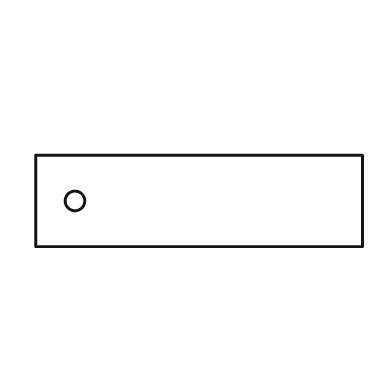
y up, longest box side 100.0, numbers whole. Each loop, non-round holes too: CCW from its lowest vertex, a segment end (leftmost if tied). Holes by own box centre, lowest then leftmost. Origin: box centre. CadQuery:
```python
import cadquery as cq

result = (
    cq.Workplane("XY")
    .moveTo(-50.0, -14.0)
    .lineTo(50.0, -14.0)
    .lineTo(50.0, 14.0)
    .lineTo(-50.0, 14.0)
    .close()
    .moveTo(-38.0, 0.0)
    .circle(3.0)
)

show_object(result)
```